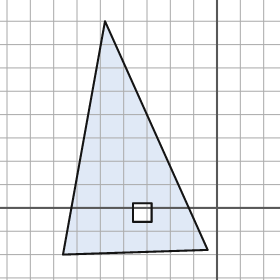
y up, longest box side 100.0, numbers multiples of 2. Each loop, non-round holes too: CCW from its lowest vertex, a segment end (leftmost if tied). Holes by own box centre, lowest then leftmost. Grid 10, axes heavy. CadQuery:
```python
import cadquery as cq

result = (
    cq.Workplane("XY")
    .moveTo(-66.0, -20.0)
    .lineTo(-4.0, -18.0)
    .lineTo(-48.0, 80.0)
    .close()
    .moveTo(-36.0, -6.0)
    .lineTo(-28.0, -6.0)
    .lineTo(-28.0, 2.0)
    .lineTo(-36.0, 2.0)
    .close()
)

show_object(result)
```